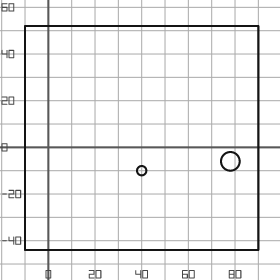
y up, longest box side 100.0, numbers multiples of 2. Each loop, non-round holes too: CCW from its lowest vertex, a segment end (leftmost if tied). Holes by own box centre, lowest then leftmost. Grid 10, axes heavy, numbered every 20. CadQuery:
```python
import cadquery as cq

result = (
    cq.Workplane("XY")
    .moveTo(-10.0, -44.0)
    .lineTo(90.0, -44.0)
    .lineTo(90.0, 52.0)
    .lineTo(-10.0, 52.0)
    .close()
    .moveTo(40.0, -10.0)
    .circle(2.0)
    .moveTo(78.0, -6.0)
    .circle(4.0)
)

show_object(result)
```